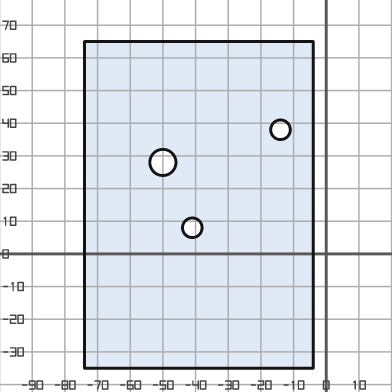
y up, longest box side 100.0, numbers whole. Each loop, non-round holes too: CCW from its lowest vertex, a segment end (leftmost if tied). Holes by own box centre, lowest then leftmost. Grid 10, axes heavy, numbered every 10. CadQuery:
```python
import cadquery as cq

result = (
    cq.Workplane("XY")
    .moveTo(-74.0, -35.0)
    .lineTo(-4.0, -35.0)
    .lineTo(-4.0, 65.0)
    .lineTo(-74.0, 65.0)
    .close()
    .moveTo(-41.0, 8.0)
    .circle(3.0)
    .moveTo(-50.0, 28.0)
    .circle(4.0)
    .moveTo(-14.0, 38.0)
    .circle(3.0)
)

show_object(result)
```